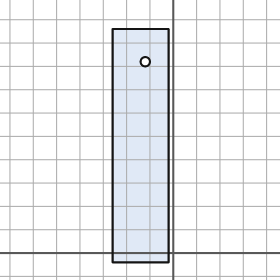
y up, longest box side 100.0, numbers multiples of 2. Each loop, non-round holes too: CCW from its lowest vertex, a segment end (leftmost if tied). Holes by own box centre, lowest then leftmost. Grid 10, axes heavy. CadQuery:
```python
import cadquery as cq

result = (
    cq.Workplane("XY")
    .moveTo(-26.0, -4.0)
    .lineTo(-2.0, -4.0)
    .lineTo(-2.0, 96.0)
    .lineTo(-26.0, 96.0)
    .close()
    .moveTo(-12.0, 82.0)
    .circle(2.0)
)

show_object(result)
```